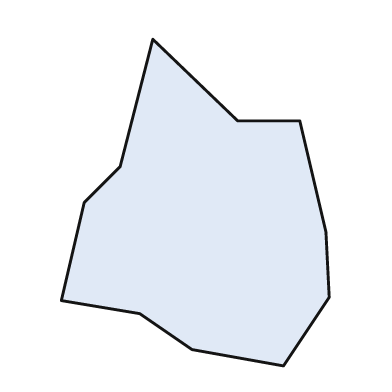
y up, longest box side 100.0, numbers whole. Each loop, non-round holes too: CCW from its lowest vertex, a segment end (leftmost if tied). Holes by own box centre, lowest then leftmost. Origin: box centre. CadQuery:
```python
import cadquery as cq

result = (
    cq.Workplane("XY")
    .moveTo(27.0, -50.0)
    .lineTo(41.0, -29.0)
    .lineTo(40.0, -9.0)
    .lineTo(32.0, 25.0)
    .lineTo(13.0, 25.0)
    .lineTo(-13.0, 50.0)
    .lineTo(-23.0, 11.0)
    .lineTo(-34.0, 0.0)
    .lineTo(-41.0, -30.0)
    .lineTo(-17.0, -34.0)
    .lineTo(-1.0, -45.0)
    .close()
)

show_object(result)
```